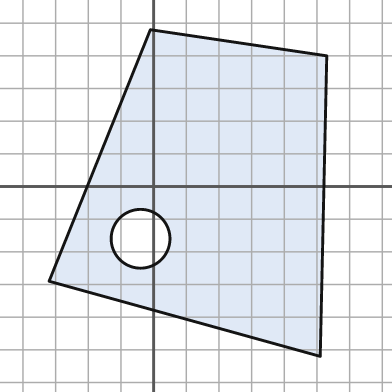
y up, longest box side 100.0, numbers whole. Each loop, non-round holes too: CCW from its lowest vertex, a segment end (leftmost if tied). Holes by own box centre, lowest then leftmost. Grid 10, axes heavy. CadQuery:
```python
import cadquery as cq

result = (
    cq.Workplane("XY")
    .moveTo(51.0, -52.0)
    .lineTo(53.0, 40.0)
    .lineTo(-1.0, 48.0)
    .lineTo(-32.0, -29.0)
    .close()
    .moveTo(-4.0, -16.0)
    .circle(9.0)
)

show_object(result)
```